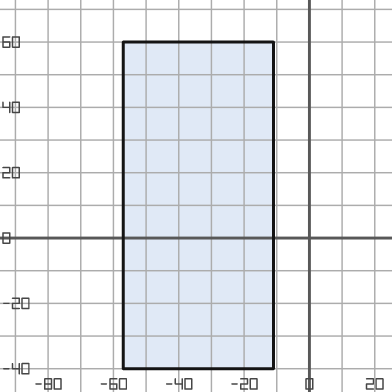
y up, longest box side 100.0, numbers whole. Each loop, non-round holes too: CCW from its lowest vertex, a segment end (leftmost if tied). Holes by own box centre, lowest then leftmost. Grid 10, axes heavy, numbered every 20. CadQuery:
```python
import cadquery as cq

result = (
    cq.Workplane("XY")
    .moveTo(-57.0, -40.0)
    .lineTo(-11.0, -40.0)
    .lineTo(-11.0, 60.0)
    .lineTo(-57.0, 60.0)
    .close()
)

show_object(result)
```